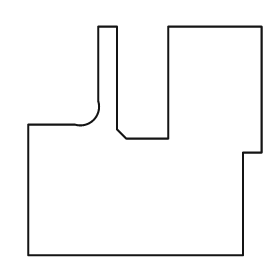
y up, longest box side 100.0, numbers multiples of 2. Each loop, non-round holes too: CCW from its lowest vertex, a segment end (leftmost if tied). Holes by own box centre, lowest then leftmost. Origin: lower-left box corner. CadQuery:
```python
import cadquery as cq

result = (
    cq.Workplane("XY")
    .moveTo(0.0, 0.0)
    .lineTo(92.0, 0.0)
    .lineTo(92.0, 44.0)
    .lineTo(100.0, 44.0)
    .lineTo(100.0, 98.0)
    .lineTo(60.0, 98.0)
    .lineTo(60.0, 50.0)
    .lineTo(42.0, 50.0)
    .lineTo(38.0, 54.0)
    .lineTo(38.0, 98.0)
    .lineTo(30.0, 98.0)
    .lineTo(30.0, 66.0)
    .threePointArc((28.0, 58.0), (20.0, 56.0))
    .lineTo(0.0, 56.0)
    .close()
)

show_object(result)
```